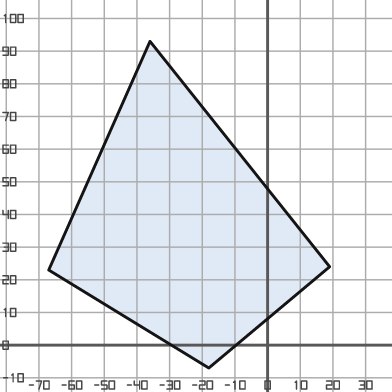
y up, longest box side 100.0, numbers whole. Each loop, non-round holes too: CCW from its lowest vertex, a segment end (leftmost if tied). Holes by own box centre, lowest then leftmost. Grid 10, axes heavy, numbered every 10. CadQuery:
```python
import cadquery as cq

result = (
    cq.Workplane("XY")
    .moveTo(-18.0, -7.0)
    .lineTo(19.0, 24.0)
    .lineTo(-36.0, 93.0)
    .lineTo(-67.0, 23.0)
    .close()
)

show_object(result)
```